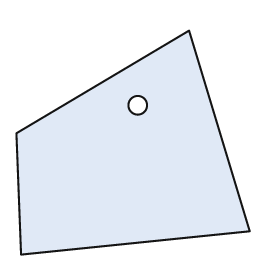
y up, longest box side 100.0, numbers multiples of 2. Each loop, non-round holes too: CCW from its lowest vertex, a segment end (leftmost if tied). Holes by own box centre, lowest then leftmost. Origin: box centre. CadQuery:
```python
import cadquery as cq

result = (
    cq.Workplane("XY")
    .moveTo(-48.0, -48.0)
    .lineTo(50.0, -38.0)
    .lineTo(24.0, 48.0)
    .lineTo(-50.0, 4.0)
    .close()
    .moveTo(2.0, 16.0)
    .circle(4.0)
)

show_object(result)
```